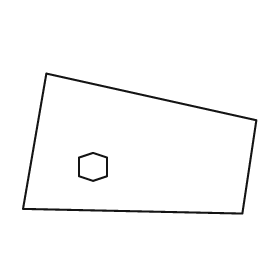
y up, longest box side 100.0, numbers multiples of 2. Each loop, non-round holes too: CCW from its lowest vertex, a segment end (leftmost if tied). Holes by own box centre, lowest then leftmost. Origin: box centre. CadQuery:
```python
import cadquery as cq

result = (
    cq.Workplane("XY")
    .moveTo(44.0, -30.0)
    .lineTo(50.0, 10.0)
    .lineTo(-40.0, 30.0)
    .lineTo(-50.0, -28.0)
    .close()
    .moveTo(-20.0, -16.0)
    .lineTo(-14.0, -14.0)
    .lineTo(-14.0, -6.0)
    .lineTo(-20.0, -4.0)
    .lineTo(-26.0, -6.0)
    .lineTo(-26.0, -14.0)
    .close()
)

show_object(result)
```